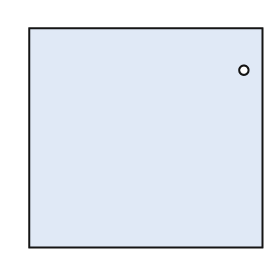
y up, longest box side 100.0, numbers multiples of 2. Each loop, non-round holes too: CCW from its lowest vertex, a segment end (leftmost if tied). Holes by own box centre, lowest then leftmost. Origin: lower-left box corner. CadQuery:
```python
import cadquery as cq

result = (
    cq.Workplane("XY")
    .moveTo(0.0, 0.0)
    .lineTo(100.0, 0.0)
    .lineTo(100.0, 94.0)
    .lineTo(0.0, 94.0)
    .close()
    .moveTo(92.0, 76.0)
    .circle(2.0)
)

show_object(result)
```